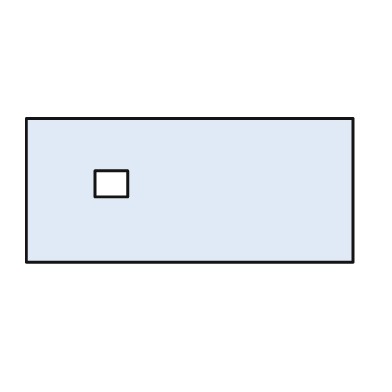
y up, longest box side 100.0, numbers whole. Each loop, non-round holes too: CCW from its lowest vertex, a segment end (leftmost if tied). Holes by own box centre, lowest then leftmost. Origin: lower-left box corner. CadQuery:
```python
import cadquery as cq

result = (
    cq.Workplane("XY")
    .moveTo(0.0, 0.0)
    .lineTo(100.0, 0.0)
    .lineTo(100.0, 44.0)
    .lineTo(0.0, 44.0)
    .close()
    .moveTo(21.0, 20.0)
    .lineTo(31.0, 20.0)
    .lineTo(31.0, 28.0)
    .lineTo(21.0, 28.0)
    .close()
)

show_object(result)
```